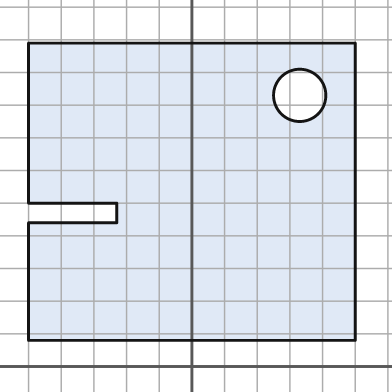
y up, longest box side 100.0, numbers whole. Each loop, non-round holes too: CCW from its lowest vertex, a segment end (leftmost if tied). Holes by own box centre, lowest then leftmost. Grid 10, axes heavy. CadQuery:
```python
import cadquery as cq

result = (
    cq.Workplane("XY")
    .moveTo(-50.0, 8.0)
    .lineTo(50.0, 8.0)
    .lineTo(50.0, 99.0)
    .lineTo(-50.0, 99.0)
    .lineTo(-50.0, 50.0)
    .lineTo(-23.0, 50.0)
    .lineTo(-23.0, 44.0)
    .lineTo(-50.0, 44.0)
    .close()
    .moveTo(33.0, 83.0)
    .circle(8.0)
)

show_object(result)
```